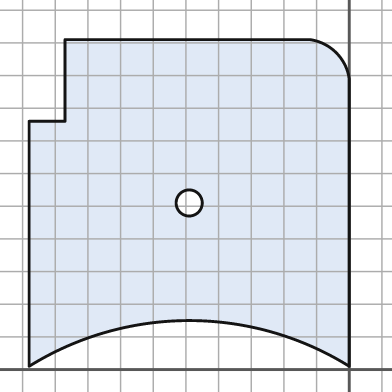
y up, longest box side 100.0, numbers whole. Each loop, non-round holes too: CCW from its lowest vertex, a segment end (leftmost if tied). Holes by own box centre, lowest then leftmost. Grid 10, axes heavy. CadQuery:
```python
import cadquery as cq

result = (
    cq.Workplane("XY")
    .moveTo(-98.0, 1.0)
    .threePointArc((-49.0, 15.0), (0.0, 1.0))
    .lineTo(0.0, 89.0)
    .threePointArc((-4.0, 97.0), (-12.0, 101.0))
    .lineTo(-87.0, 101.0)
    .lineTo(-87.0, 76.0)
    .lineTo(-98.0, 76.0)
    .close()
    .moveTo(-49.0, 51.0)
    .circle(4.0)
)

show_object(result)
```